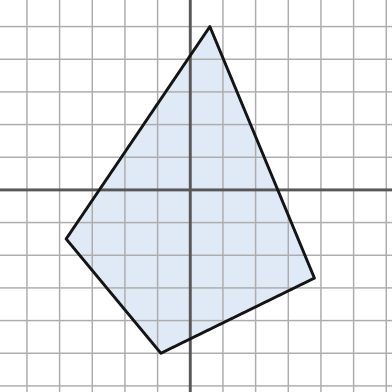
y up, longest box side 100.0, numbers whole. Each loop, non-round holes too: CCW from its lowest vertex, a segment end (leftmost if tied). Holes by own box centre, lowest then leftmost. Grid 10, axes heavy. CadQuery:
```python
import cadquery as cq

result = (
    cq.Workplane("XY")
    .moveTo(-9.0, -50.0)
    .lineTo(38.0, -27.0)
    .lineTo(6.0, 50.0)
    .lineTo(-38.0, -15.0)
    .close()
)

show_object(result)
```